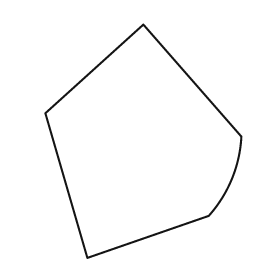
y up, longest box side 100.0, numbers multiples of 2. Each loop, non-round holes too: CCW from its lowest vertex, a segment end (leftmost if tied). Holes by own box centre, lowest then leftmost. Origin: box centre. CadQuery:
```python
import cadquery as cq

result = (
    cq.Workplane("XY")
    .moveTo(-24.0, -50.0)
    .lineTo(28.0, -32.0)
    .threePointArc((38.0, -16.0), (42.0, 2.0))
    .lineTo(0.0, 50.0)
    .lineTo(-42.0, 12.0)
    .close()
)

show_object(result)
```